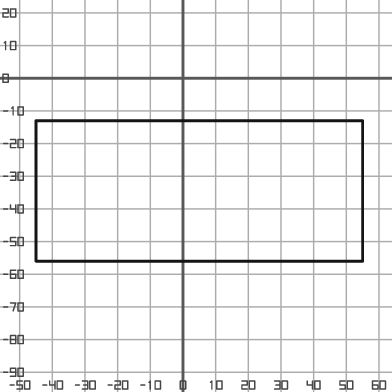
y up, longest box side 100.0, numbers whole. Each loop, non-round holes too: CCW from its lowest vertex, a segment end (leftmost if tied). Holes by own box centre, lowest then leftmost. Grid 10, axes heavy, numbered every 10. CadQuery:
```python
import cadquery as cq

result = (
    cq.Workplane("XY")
    .moveTo(-45.0, -56.0)
    .lineTo(55.0, -56.0)
    .lineTo(55.0, -13.0)
    .lineTo(-45.0, -13.0)
    .close()
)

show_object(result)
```